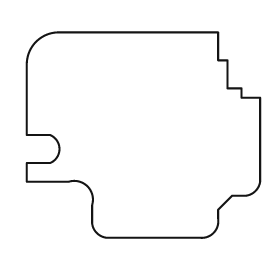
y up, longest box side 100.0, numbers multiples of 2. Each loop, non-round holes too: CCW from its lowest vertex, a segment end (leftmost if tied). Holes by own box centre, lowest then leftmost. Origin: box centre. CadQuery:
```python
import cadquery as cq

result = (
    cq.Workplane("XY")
    .moveTo(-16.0, -44.0)
    .lineTo(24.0, -44.0)
    .threePointArc((30.0, -42.0), (32.0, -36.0))
    .lineTo(32.0, -32.0)
    .lineTo(38.0, -26.0)
    .lineTo(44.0, -26.0)
    .threePointArc((48.0, -24.0), (50.0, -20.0))
    .lineTo(50.0, 16.0)
    .lineTo(42.0, 16.0)
    .lineTo(42.0, 20.0)
    .lineTo(36.0, 20.0)
    .lineTo(36.0, 32.0)
    .lineTo(32.0, 32.0)
    .lineTo(32.0, 44.0)
    .lineTo(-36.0, 44.0)
    .threePointArc((-46.0, 40.0), (-50.0, 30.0))
    .lineTo(-50.0, 0.0)
    .lineTo(-40.0, 0.0)
    .threePointArc((-36.0, -6.0), (-40.0, -12.0))
    .lineTo(-50.0, -12.0)
    .lineTo(-50.0, -20.0)
    .lineTo(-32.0, -20.0)
    .threePointArc((-24.0, -22.0), (-22.0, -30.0))
    .lineTo(-22.0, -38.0)
    .threePointArc((-20.0, -42.0), (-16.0, -44.0))
    .close()
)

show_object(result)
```